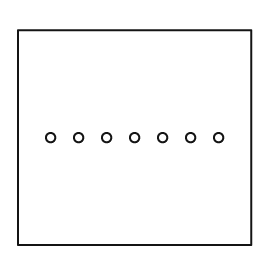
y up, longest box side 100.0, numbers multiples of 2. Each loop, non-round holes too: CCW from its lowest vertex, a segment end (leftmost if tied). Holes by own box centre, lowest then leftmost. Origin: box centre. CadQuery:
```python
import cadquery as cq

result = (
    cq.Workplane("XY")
    .moveTo(-50.0, -46.0)
    .lineTo(50.0, -46.0)
    .lineTo(50.0, 46.0)
    .lineTo(-50.0, 46.0)
    .close()
    .moveTo(-36.0, 0.0)
    .circle(2.0)
    .moveTo(-24.0, 0.0)
    .circle(2.0)
    .moveTo(-12.0, 0.0)
    .circle(2.0)
    .moveTo(0.0, 0.0)
    .circle(2.0)
    .moveTo(12.0, 0.0)
    .circle(2.0)
    .moveTo(24.0, 0.0)
    .circle(2.0)
    .moveTo(36.0, 0.0)
    .circle(2.0)
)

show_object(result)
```